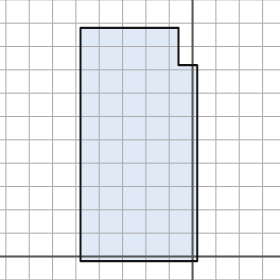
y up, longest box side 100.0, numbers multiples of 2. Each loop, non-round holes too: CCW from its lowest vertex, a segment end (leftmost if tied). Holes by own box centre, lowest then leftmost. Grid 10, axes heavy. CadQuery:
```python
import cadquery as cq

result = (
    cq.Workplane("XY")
    .moveTo(-48.0, -2.0)
    .lineTo(2.0, -2.0)
    .lineTo(2.0, 82.0)
    .lineTo(-6.0, 82.0)
    .lineTo(-6.0, 98.0)
    .lineTo(-48.0, 98.0)
    .close()
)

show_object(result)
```